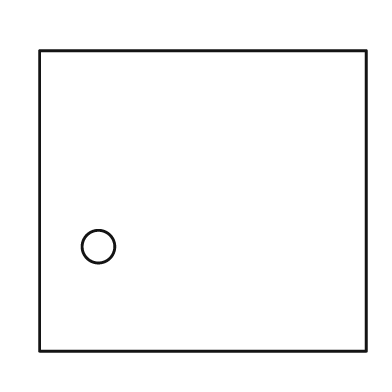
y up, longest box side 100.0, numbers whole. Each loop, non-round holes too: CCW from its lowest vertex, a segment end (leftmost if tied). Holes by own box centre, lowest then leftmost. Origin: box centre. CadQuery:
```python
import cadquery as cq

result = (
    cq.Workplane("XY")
    .moveTo(-50.0, -46.0)
    .lineTo(50.0, -46.0)
    .lineTo(50.0, 46.0)
    .lineTo(-50.0, 46.0)
    .close()
    .moveTo(-32.0, -14.0)
    .circle(5.0)
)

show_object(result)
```